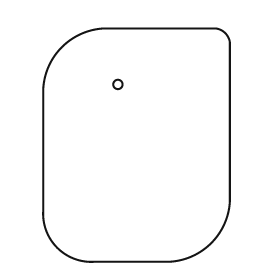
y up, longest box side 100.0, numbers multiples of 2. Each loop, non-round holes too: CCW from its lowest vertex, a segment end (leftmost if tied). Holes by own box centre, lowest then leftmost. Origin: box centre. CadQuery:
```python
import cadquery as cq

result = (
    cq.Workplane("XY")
    .moveTo(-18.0, -50.0)
    .lineTo(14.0, -50.0)
    .threePointArc((32.0, -42.0), (40.0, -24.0))
    .lineTo(40.0, 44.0)
    .threePointArc((38.0, 48.0), (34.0, 50.0))
    .lineTo(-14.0, 50.0)
    .threePointArc((-32.0, 42.0), (-40.0, 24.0))
    .lineTo(-40.0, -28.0)
    .threePointArc((-34.0, -44.0), (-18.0, -50.0))
    .close()
    .moveTo(-8.0, 26.0)
    .circle(2.0)
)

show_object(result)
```